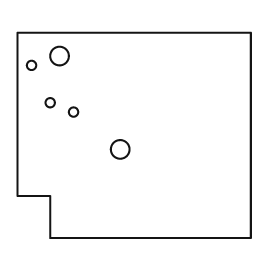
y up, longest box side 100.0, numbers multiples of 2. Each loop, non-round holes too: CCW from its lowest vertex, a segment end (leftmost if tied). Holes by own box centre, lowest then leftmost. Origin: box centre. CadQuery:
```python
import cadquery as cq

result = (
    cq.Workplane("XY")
    .moveTo(-36.0, -44.0)
    .lineTo(50.0, -44.0)
    .lineTo(50.0, 44.0)
    .lineTo(-50.0, 44.0)
    .lineTo(-50.0, -26.0)
    .lineTo(-36.0, -26.0)
    .close()
    .moveTo(-6.0, -6.0)
    .circle(4.0)
    .moveTo(-26.0, 10.0)
    .circle(2.0)
    .moveTo(-36.0, 14.0)
    .circle(2.0)
    .moveTo(-44.0, 30.0)
    .circle(2.0)
    .moveTo(-32.0, 34.0)
    .circle(4.0)
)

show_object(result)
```